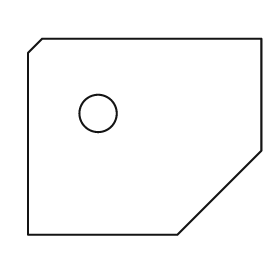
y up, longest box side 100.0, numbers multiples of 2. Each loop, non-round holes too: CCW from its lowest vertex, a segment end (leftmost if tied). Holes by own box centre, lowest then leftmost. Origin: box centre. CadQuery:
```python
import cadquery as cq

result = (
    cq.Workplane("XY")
    .moveTo(-50.0, -42.0)
    .lineTo(14.0, -42.0)
    .lineTo(50.0, -6.0)
    .lineTo(50.0, 42.0)
    .lineTo(-44.0, 42.0)
    .lineTo(-50.0, 36.0)
    .close()
    .moveTo(-20.0, 10.0)
    .circle(8.0)
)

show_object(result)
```